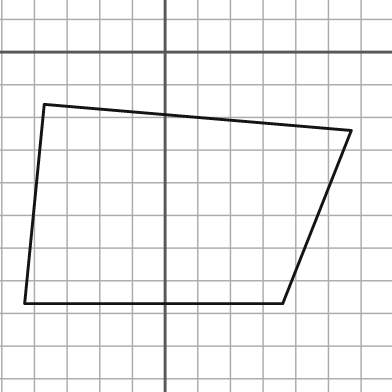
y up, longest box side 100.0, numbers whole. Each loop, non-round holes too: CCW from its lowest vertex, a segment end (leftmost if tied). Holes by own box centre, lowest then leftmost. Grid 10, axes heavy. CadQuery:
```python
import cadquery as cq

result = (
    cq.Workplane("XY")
    .moveTo(-43.0, -77.0)
    .lineTo(36.0, -77.0)
    .lineTo(57.0, -24.0)
    .lineTo(-37.0, -16.0)
    .close()
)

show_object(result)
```